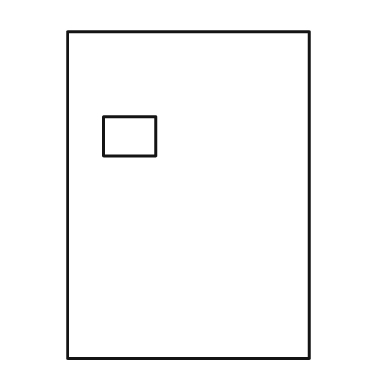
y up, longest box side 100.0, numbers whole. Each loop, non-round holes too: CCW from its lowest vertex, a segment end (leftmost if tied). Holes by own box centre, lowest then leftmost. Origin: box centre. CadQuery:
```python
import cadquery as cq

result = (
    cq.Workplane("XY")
    .moveTo(-37.0, -50.0)
    .lineTo(37.0, -50.0)
    .lineTo(37.0, 50.0)
    .lineTo(-37.0, 50.0)
    .close()
    .moveTo(-26.0, 12.0)
    .lineTo(-10.0, 12.0)
    .lineTo(-10.0, 24.0)
    .lineTo(-26.0, 24.0)
    .close()
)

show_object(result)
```